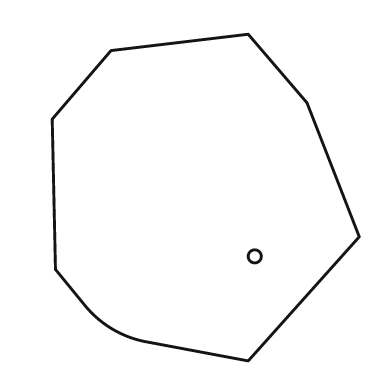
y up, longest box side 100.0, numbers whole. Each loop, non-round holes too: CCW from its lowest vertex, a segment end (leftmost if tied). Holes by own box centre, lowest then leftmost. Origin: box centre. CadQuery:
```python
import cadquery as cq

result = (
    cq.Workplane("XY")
    .moveTo(13.0, -50.0)
    .lineTo(47.0, -12.0)
    .lineTo(31.0, 29.0)
    .lineTo(13.0, 50.0)
    .lineTo(-29.0, 45.0)
    .lineTo(-47.0, 24.0)
    .lineTo(-46.0, -22.0)
    .lineTo(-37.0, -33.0)
    .threePointArc((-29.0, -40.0), (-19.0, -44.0))
    .close()
    .moveTo(15.0, -18.0)
    .circle(2.0)
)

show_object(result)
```